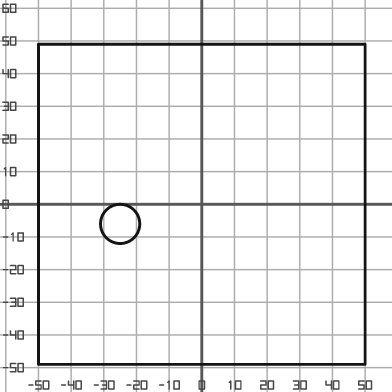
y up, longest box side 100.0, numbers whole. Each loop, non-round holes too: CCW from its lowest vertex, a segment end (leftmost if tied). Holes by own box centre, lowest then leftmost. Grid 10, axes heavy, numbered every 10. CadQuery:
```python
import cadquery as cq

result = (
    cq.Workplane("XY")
    .moveTo(-50.0, -49.0)
    .lineTo(50.0, -49.0)
    .lineTo(50.0, 49.0)
    .lineTo(-50.0, 49.0)
    .close()
    .moveTo(-25.0, -6.0)
    .circle(6.0)
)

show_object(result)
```